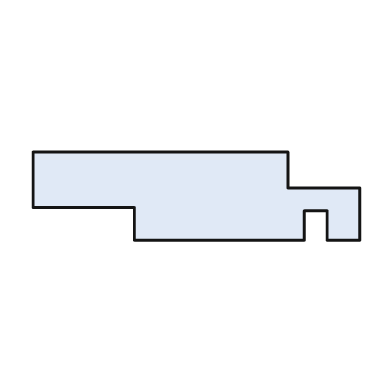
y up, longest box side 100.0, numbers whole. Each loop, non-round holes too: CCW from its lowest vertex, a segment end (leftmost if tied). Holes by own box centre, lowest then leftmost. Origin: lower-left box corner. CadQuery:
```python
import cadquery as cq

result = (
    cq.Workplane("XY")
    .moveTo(31.0, 0.0)
    .lineTo(83.0, 0.0)
    .lineTo(83.0, 9.0)
    .lineTo(90.0, 9.0)
    .lineTo(90.0, 0.0)
    .lineTo(100.0, 0.0)
    .lineTo(100.0, 16.0)
    .lineTo(78.0, 16.0)
    .lineTo(78.0, 27.0)
    .lineTo(0.0, 27.0)
    .lineTo(0.0, 10.0)
    .lineTo(31.0, 10.0)
    .close()
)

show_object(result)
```